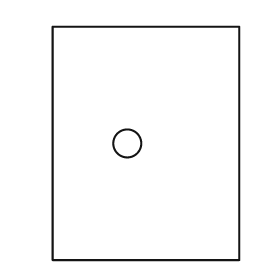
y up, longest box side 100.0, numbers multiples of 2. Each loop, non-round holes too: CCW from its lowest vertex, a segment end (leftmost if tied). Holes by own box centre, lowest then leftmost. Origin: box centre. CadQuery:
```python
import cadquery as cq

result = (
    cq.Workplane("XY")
    .moveTo(-40.0, -50.0)
    .lineTo(40.0, -50.0)
    .lineTo(40.0, 50.0)
    .lineTo(-40.0, 50.0)
    .close()
    .moveTo(-8.0, 0.0)
    .circle(6.0)
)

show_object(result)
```